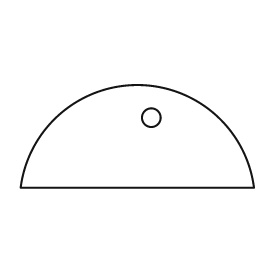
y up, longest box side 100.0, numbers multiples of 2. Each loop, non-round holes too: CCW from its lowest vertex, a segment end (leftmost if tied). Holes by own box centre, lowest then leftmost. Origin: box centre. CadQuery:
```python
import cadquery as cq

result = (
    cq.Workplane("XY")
    .moveTo(-50.0, -22.0)
    .lineTo(50.0, -22.0)
    .threePointArc((0.0, 22.0), (-50.0, -22.0))
    .close()
    .moveTo(6.0, 8.0)
    .circle(4.0)
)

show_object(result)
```